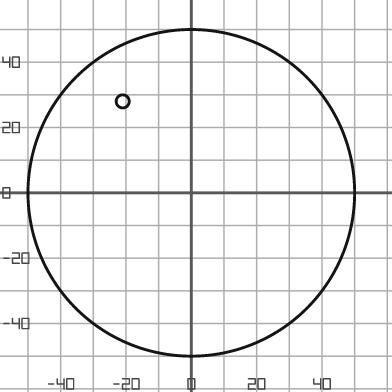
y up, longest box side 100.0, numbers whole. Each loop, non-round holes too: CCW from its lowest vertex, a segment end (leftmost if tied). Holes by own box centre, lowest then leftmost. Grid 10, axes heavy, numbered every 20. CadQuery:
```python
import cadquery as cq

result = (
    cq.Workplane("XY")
    .moveTo(0.0, 0.0)
    .circle(50.0)
    .moveTo(-21.0, 28.0)
    .circle(2.0)
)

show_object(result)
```